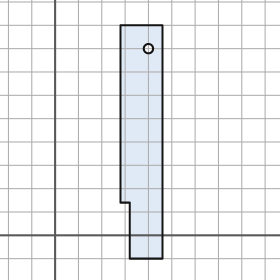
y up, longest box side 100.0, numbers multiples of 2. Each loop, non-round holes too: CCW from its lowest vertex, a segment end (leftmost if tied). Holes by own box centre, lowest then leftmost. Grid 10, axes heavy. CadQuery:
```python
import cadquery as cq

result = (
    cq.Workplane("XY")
    .moveTo(32.0, -10.0)
    .lineTo(46.0, -10.0)
    .lineTo(46.0, 90.0)
    .lineTo(28.0, 90.0)
    .lineTo(28.0, 14.0)
    .lineTo(32.0, 14.0)
    .close()
    .moveTo(40.0, 80.0)
    .circle(2.0)
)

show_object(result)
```